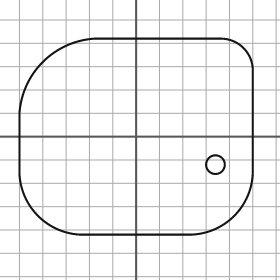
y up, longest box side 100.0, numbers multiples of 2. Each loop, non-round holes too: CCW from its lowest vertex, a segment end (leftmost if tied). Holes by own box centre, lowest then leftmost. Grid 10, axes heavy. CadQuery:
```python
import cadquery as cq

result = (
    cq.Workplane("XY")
    .moveTo(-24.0, -42.0)
    .lineTo(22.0, -42.0)
    .threePointArc((42.0, -34.0), (50.0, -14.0))
    .lineTo(50.0, 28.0)
    .threePointArc((46.0, 38.0), (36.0, 42.0))
    .lineTo(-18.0, 42.0)
    .threePointArc((-40.0, 32.0), (-50.0, 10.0))
    .lineTo(-50.0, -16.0)
    .threePointArc((-42.0, -34.0), (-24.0, -42.0))
    .close()
    .moveTo(34.0, -12.0)
    .circle(4.0)
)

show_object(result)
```